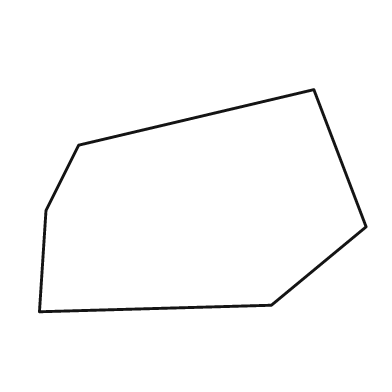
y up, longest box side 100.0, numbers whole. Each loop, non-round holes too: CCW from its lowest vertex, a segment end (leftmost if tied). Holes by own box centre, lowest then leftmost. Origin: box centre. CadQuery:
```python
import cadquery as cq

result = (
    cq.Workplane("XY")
    .moveTo(-50.0, -34.0)
    .lineTo(21.0, -32.0)
    .lineTo(50.0, -8.0)
    .lineTo(34.0, 34.0)
    .lineTo(-38.0, 17.0)
    .lineTo(-48.0, -3.0)
    .close()
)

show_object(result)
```